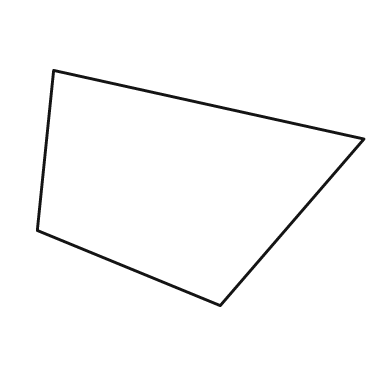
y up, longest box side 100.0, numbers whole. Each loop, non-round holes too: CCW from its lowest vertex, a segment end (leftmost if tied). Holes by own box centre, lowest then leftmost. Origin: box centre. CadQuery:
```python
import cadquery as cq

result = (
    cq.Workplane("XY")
    .moveTo(6.0, -36.0)
    .lineTo(50.0, 15.0)
    .lineTo(-45.0, 36.0)
    .lineTo(-50.0, -13.0)
    .close()
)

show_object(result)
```